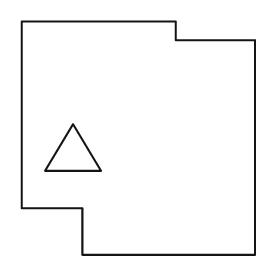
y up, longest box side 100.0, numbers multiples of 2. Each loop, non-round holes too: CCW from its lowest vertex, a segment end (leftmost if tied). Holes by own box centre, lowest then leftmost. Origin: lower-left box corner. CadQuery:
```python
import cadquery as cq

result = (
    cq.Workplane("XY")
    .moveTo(26.0, 0.0)
    .lineTo(100.0, 0.0)
    .lineTo(100.0, 92.0)
    .lineTo(66.0, 92.0)
    .lineTo(66.0, 100.0)
    .lineTo(0.0, 100.0)
    .lineTo(0.0, 20.0)
    .lineTo(26.0, 20.0)
    .close()
    .moveTo(10.0, 36.0)
    .lineTo(34.0, 36.0)
    .lineTo(22.0, 56.0)
    .close()
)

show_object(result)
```